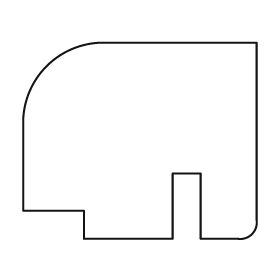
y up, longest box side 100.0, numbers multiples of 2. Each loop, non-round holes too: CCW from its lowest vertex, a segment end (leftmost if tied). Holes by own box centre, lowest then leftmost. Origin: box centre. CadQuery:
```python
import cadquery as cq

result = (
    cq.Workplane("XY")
    .moveTo(-24.0, -42.0)
    .lineTo(14.0, -42.0)
    .lineTo(14.0, -14.0)
    .lineTo(26.0, -14.0)
    .lineTo(26.0, -42.0)
    .lineTo(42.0, -42.0)
    .threePointArc((48.0, -40.0), (50.0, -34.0))
    .lineTo(50.0, 42.0)
    .lineTo(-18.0, 42.0)
    .threePointArc((-40.0, 32.0), (-50.0, 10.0))
    .lineTo(-50.0, -30.0)
    .lineTo(-24.0, -30.0)
    .close()
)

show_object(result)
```